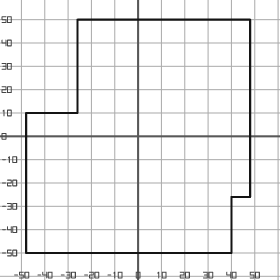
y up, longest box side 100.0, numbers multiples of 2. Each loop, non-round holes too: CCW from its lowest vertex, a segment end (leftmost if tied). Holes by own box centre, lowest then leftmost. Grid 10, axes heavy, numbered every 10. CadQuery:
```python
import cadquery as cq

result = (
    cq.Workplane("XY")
    .moveTo(-48.0, -50.0)
    .lineTo(40.0, -50.0)
    .lineTo(40.0, -26.0)
    .lineTo(48.0, -26.0)
    .lineTo(48.0, 50.0)
    .lineTo(-26.0, 50.0)
    .lineTo(-26.0, 10.0)
    .lineTo(-48.0, 10.0)
    .close()
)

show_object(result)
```